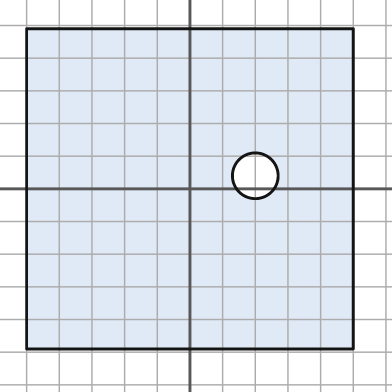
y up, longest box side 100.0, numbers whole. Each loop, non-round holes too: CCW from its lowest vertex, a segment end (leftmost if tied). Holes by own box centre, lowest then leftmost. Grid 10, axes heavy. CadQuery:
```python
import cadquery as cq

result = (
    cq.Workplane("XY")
    .moveTo(-50.0, -49.0)
    .lineTo(50.0, -49.0)
    .lineTo(50.0, 49.0)
    .lineTo(-50.0, 49.0)
    .close()
    .moveTo(20.0, 4.0)
    .circle(7.0)
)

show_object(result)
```